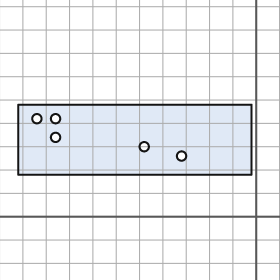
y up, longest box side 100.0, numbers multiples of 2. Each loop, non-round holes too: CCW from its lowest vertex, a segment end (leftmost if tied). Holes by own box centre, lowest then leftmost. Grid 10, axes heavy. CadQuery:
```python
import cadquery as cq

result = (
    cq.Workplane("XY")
    .moveTo(-102.0, 18.0)
    .lineTo(-2.0, 18.0)
    .lineTo(-2.0, 48.0)
    .lineTo(-102.0, 48.0)
    .close()
    .moveTo(-32.0, 26.0)
    .circle(2.0)
    .moveTo(-48.0, 30.0)
    .circle(2.0)
    .moveTo(-86.0, 34.0)
    .circle(2.0)
    .moveTo(-94.0, 42.0)
    .circle(2.0)
    .moveTo(-86.0, 42.0)
    .circle(2.0)
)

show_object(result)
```